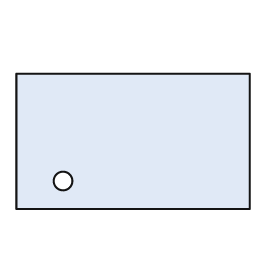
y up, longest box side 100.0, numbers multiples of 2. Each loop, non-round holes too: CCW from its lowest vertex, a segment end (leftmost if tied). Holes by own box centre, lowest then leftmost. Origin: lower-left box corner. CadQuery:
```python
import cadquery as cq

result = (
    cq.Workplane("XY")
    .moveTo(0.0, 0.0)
    .lineTo(100.0, 0.0)
    .lineTo(100.0, 58.0)
    .lineTo(0.0, 58.0)
    .close()
    .moveTo(20.0, 12.0)
    .circle(4.0)
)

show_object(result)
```